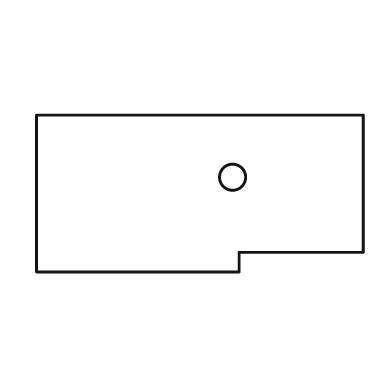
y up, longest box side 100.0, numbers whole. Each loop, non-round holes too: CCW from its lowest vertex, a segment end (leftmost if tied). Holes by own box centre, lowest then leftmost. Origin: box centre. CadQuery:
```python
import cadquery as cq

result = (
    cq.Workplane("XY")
    .moveTo(-50.0, -24.0)
    .lineTo(12.0, -24.0)
    .lineTo(12.0, -18.0)
    .lineTo(50.0, -18.0)
    .lineTo(50.0, 24.0)
    .lineTo(-50.0, 24.0)
    .close()
    .moveTo(10.0, 5.0)
    .circle(4.0)
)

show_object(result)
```